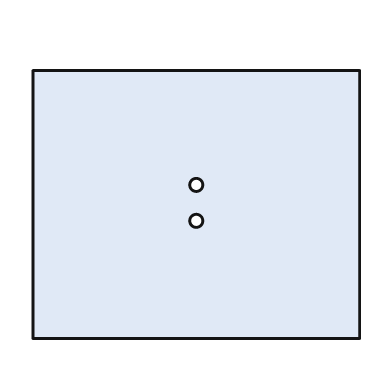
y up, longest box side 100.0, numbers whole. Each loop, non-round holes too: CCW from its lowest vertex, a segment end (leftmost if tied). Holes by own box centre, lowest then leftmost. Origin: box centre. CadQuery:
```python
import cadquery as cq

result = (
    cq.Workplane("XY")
    .moveTo(-50.0, -41.0)
    .lineTo(50.0, -41.0)
    .lineTo(50.0, 41.0)
    .lineTo(-50.0, 41.0)
    .close()
    .moveTo(0.0, -5.0)
    .circle(2.0)
    .moveTo(0.0, 6.0)
    .circle(2.0)
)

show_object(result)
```